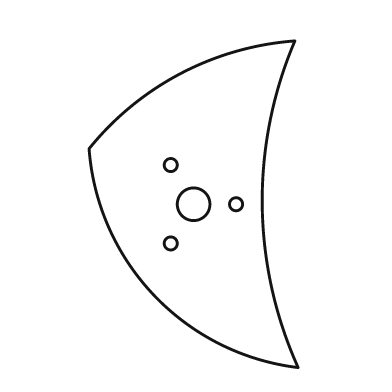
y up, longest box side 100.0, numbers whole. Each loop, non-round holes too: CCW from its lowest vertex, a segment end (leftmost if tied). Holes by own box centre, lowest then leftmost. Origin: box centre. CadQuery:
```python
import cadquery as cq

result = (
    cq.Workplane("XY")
    .moveTo(32.0, -50.0)
    .threePointArc((21.0, 0.0), (31.0, 50.0))
    .threePointArc((-4.0, 40.0), (-32.0, 17.0))
    .threePointArc((-12.0, -28.0), (32.0, -50.0))
    .close()
    .moveTo(-7.0, -12.0)
    .circle(2.0)
    .moveTo(0.0, 0.0)
    .circle(5.0)
    .moveTo(13.0, 0.0)
    .circle(2.0)
    .moveTo(-7.0, 12.0)
    .circle(2.0)
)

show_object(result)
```